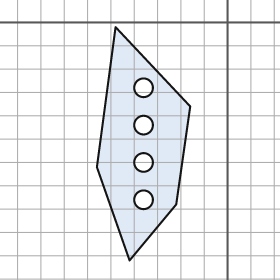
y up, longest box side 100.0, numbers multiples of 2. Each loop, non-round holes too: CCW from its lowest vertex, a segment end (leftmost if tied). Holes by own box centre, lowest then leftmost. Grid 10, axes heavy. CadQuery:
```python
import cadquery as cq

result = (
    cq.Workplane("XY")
    .moveTo(-42.0, -102.0)
    .lineTo(-22.0, -78.0)
    .lineTo(-16.0, -36.0)
    .lineTo(-48.0, -2.0)
    .lineTo(-56.0, -62.0)
    .close()
    .moveTo(-36.0, -76.0)
    .circle(4.0)
    .moveTo(-36.0, -60.0)
    .circle(4.0)
    .moveTo(-36.0, -44.0)
    .circle(4.0)
    .moveTo(-36.0, -28.0)
    .circle(4.0)
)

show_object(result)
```